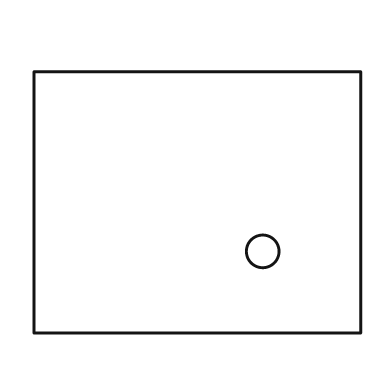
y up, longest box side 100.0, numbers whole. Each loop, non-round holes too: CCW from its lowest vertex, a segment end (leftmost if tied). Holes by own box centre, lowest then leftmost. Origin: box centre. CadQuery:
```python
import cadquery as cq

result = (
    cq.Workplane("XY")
    .moveTo(-50.0, -40.0)
    .lineTo(50.0, -40.0)
    .lineTo(50.0, 40.0)
    .lineTo(-50.0, 40.0)
    .close()
    .moveTo(20.0, -15.0)
    .circle(5.0)
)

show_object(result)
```